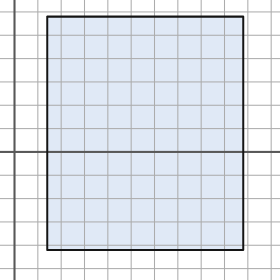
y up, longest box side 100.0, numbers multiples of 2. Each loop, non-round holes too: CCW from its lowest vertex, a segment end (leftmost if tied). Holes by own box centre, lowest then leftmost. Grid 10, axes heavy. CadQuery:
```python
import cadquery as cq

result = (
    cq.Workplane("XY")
    .moveTo(14.0, -42.0)
    .lineTo(98.0, -42.0)
    .lineTo(98.0, 58.0)
    .lineTo(14.0, 58.0)
    .close()
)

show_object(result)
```